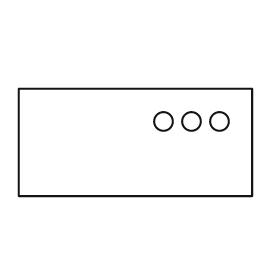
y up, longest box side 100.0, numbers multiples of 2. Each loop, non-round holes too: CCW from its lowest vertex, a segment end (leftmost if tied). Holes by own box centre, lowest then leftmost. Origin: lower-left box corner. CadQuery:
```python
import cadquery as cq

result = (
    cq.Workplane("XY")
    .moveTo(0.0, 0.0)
    .lineTo(100.0, 0.0)
    .lineTo(100.0, 46.0)
    .lineTo(0.0, 46.0)
    .close()
    .moveTo(62.0, 32.0)
    .circle(4.0)
    .moveTo(74.0, 32.0)
    .circle(4.0)
    .moveTo(86.0, 32.0)
    .circle(4.0)
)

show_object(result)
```